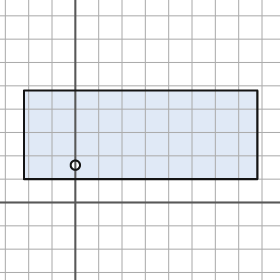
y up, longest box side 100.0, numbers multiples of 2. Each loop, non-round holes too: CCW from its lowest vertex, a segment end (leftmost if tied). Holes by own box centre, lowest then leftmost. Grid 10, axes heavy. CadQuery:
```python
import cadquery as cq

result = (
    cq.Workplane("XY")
    .moveTo(-22.0, 10.0)
    .lineTo(78.0, 10.0)
    .lineTo(78.0, 48.0)
    .lineTo(-22.0, 48.0)
    .close()
    .moveTo(0.0, 16.0)
    .circle(2.0)
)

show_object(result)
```